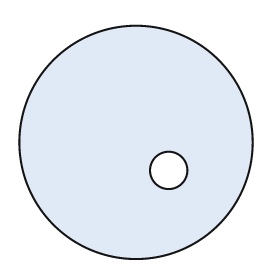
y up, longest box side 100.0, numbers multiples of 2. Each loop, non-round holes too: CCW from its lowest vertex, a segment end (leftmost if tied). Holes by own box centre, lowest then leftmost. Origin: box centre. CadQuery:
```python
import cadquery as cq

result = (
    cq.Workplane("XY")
    .moveTo(0.0, 0.0)
    .circle(50.0)
    .moveTo(14.0, -12.0)
    .circle(8.0)
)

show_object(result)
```